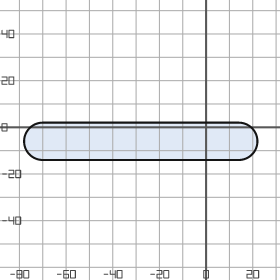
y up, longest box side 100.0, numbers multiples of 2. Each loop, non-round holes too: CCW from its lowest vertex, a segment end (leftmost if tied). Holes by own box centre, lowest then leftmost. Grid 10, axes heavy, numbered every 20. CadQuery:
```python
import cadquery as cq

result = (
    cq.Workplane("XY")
    .moveTo(-70.0, -14.0)
    .lineTo(14.0, -14.0)
    .threePointArc((22.0, -6.0), (14.0, 2.0))
    .lineTo(-70.0, 2.0)
    .threePointArc((-78.0, -6.0), (-70.0, -14.0))
    .close()
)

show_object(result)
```